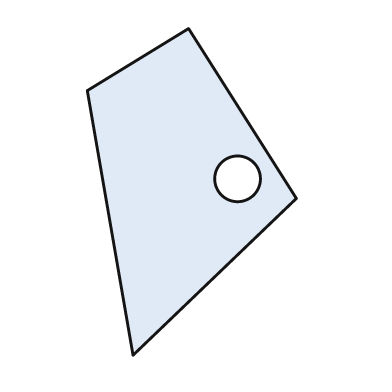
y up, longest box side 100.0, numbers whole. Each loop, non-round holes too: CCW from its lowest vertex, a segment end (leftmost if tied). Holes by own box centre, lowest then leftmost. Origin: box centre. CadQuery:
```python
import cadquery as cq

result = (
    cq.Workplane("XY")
    .moveTo(-18.0, -50.0)
    .lineTo(32.0, -2.0)
    .lineTo(-1.0, 50.0)
    .lineTo(-32.0, 31.0)
    .close()
    .moveTo(14.0, 4.0)
    .circle(7.0)
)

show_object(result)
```